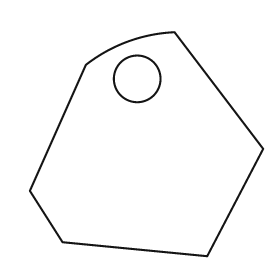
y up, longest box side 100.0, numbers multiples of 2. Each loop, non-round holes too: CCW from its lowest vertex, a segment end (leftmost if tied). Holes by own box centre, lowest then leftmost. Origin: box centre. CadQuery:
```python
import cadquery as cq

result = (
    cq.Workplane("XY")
    .moveTo(26.0, -48.0)
    .lineTo(50.0, -2.0)
    .lineTo(12.0, 48.0)
    .threePointArc((-8.0, 44.0), (-26.0, 34.0))
    .lineTo(-50.0, -20.0)
    .lineTo(-36.0, -42.0)
    .close()
    .moveTo(-4.0, 28.0)
    .circle(10.0)
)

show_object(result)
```